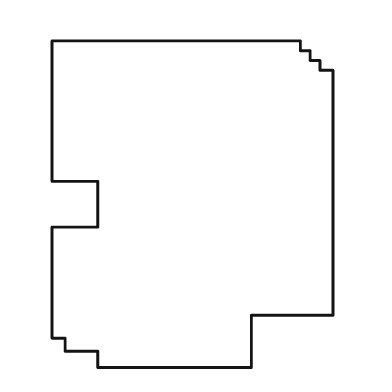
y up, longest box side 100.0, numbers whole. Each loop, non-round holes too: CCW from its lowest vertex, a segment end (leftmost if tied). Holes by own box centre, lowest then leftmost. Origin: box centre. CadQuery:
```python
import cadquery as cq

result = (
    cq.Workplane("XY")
    .moveTo(-29.0, -50.0)
    .lineTo(18.0, -50.0)
    .lineTo(18.0, -34.0)
    .lineTo(43.0, -34.0)
    .lineTo(43.0, 41.0)
    .lineTo(39.0, 41.0)
    .lineTo(39.0, 44.0)
    .lineTo(36.0, 44.0)
    .lineTo(36.0, 47.0)
    .lineTo(33.0, 47.0)
    .lineTo(33.0, 50.0)
    .lineTo(-43.0, 50.0)
    .lineTo(-43.0, 7.0)
    .lineTo(-29.0, 7.0)
    .lineTo(-29.0, -7.0)
    .lineTo(-43.0, -7.0)
    .lineTo(-43.0, -41.0)
    .lineTo(-39.0, -41.0)
    .lineTo(-39.0, -45.0)
    .lineTo(-29.0, -45.0)
    .close()
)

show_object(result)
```